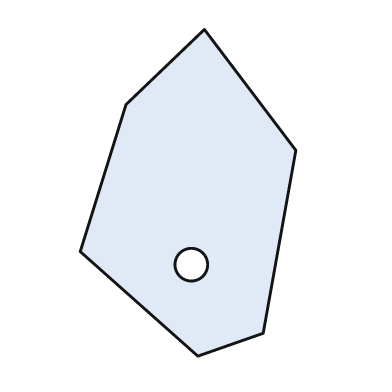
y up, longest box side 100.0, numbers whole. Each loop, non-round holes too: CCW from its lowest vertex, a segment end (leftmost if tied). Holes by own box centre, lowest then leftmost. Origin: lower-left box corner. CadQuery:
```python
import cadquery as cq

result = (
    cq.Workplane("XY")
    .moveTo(36.0, 0.0)
    .lineTo(56.0, 7.0)
    .lineTo(66.0, 63.0)
    .lineTo(38.0, 100.0)
    .lineTo(14.0, 77.0)
    .lineTo(0.0, 32.0)
    .close()
    .moveTo(34.0, 28.0)
    .circle(5.0)
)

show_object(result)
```